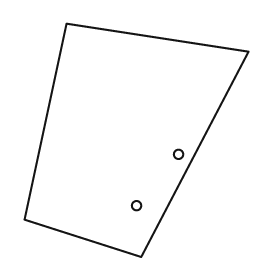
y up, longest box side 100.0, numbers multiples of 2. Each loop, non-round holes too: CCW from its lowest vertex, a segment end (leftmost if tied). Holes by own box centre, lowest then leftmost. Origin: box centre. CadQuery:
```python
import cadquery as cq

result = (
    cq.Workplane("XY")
    .moveTo(2.0, -50.0)
    .lineTo(48.0, 38.0)
    .lineTo(-30.0, 50.0)
    .lineTo(-48.0, -34.0)
    .close()
    .moveTo(0.0, -28.0)
    .circle(2.0)
    .moveTo(18.0, -6.0)
    .circle(2.0)
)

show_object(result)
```